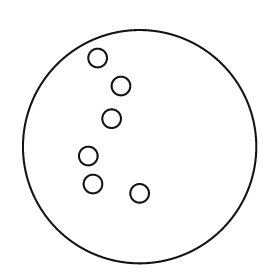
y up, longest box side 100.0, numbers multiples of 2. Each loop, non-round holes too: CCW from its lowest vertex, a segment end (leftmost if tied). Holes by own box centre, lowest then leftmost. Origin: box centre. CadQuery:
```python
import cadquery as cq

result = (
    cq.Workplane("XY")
    .moveTo(0.0, 0.0)
    .circle(50.0)
    .moveTo(0.0, -20.0)
    .circle(4.0)
    .moveTo(-20.0, -16.0)
    .circle(4.0)
    .moveTo(-22.0, -4.0)
    .circle(4.0)
    .moveTo(-12.0, 12.0)
    .circle(4.0)
    .moveTo(-8.0, 26.0)
    .circle(4.0)
    .moveTo(-18.0, 38.0)
    .circle(4.0)
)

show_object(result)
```